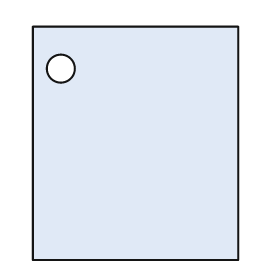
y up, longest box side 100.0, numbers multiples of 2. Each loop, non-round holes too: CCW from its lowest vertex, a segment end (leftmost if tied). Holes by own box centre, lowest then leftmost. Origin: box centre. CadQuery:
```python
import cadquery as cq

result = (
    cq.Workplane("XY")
    .moveTo(-44.0, -50.0)
    .lineTo(44.0, -50.0)
    .lineTo(44.0, 50.0)
    .lineTo(-44.0, 50.0)
    .close()
    .moveTo(-32.0, 32.0)
    .circle(6.0)
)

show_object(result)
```